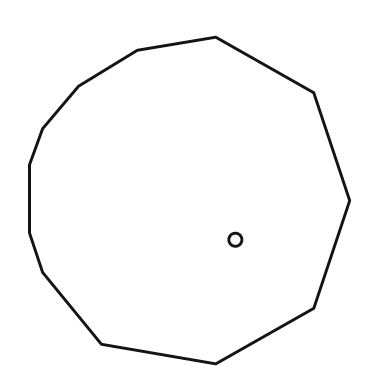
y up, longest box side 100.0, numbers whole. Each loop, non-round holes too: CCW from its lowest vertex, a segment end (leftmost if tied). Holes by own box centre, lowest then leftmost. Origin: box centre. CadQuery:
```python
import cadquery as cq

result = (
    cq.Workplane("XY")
    .moveTo(8.0, -50.0)
    .lineTo(38.0, -33.0)
    .lineTo(49.0, 0.0)
    .lineTo(38.0, 33.0)
    .lineTo(8.0, 50.0)
    .lineTo(-16.0, 46.0)
    .lineTo(-34.0, 35.0)
    .lineTo(-45.0, 22.0)
    .lineTo(-49.0, 11.0)
    .lineTo(-49.0, -10.0)
    .lineTo(-45.0, -22.0)
    .lineTo(-27.0, -44.0)
    .close()
    .moveTo(14.0, -12.0)
    .circle(2.0)
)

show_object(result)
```